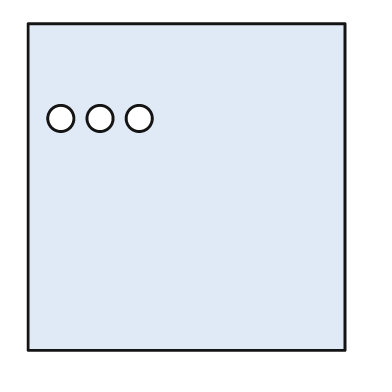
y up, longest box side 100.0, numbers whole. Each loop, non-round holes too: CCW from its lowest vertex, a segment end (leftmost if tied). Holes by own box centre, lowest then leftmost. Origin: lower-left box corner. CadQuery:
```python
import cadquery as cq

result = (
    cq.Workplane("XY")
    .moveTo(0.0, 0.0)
    .lineTo(97.0, 0.0)
    .lineTo(97.0, 100.0)
    .lineTo(0.0, 100.0)
    .close()
    .moveTo(10.0, 71.0)
    .circle(4.0)
    .moveTo(22.0, 71.0)
    .circle(4.0)
    .moveTo(34.0, 71.0)
    .circle(4.0)
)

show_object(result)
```